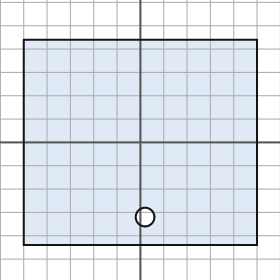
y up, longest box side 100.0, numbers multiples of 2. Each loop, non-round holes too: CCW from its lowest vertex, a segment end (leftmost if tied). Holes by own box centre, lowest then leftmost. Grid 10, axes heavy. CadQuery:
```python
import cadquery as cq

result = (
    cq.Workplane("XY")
    .moveTo(-50.0, -44.0)
    .lineTo(50.0, -44.0)
    .lineTo(50.0, 44.0)
    .lineTo(-50.0, 44.0)
    .close()
    .moveTo(2.0, -32.0)
    .circle(4.0)
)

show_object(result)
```